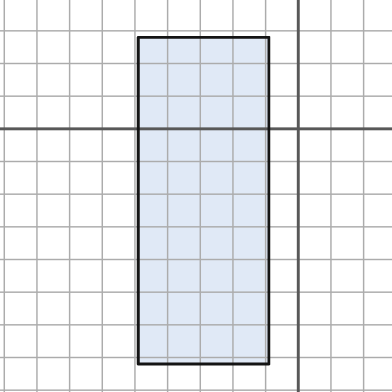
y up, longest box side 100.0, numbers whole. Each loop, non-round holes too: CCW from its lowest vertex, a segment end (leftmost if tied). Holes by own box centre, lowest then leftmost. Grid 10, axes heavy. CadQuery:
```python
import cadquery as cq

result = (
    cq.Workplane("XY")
    .moveTo(-49.0, -72.0)
    .lineTo(-9.0, -72.0)
    .lineTo(-9.0, 28.0)
    .lineTo(-49.0, 28.0)
    .close()
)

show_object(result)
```